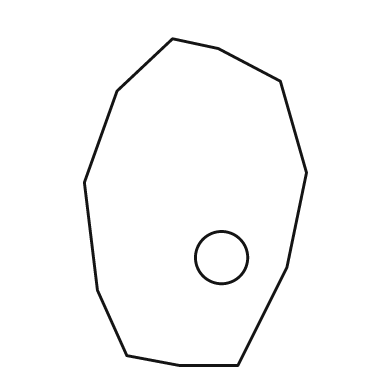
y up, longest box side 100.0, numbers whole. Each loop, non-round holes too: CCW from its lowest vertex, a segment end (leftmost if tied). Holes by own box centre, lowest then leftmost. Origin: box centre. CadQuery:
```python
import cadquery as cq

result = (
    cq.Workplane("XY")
    .moveTo(-5.0, -50.0)
    .lineTo(13.0, -50.0)
    .lineTo(28.0, -20.0)
    .lineTo(34.0, 9.0)
    .lineTo(26.0, 37.0)
    .lineTo(7.0, 47.0)
    .lineTo(-7.0, 50.0)
    .lineTo(-24.0, 34.0)
    .lineTo(-34.0, 6.0)
    .lineTo(-30.0, -27.0)
    .lineTo(-21.0, -47.0)
    .close()
    .moveTo(8.0, -17.0)
    .circle(8.0)
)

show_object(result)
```